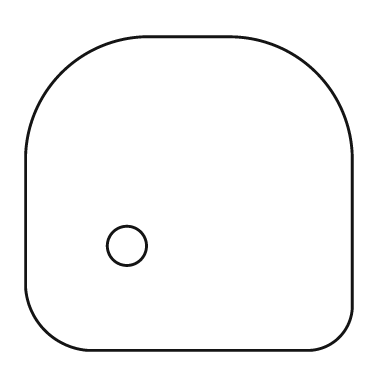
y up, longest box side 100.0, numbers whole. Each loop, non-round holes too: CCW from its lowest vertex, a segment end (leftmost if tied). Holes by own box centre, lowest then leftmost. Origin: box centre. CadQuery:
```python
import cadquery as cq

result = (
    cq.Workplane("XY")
    .moveTo(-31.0, -48.0)
    .lineTo(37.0, -48.0)
    .threePointArc((46.0, -44.0), (50.0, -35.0))
    .lineTo(50.0, 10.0)
    .threePointArc((39.0, 37.0), (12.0, 48.0))
    .lineTo(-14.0, 48.0)
    .threePointArc((-39.0, 37.0), (-50.0, 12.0))
    .lineTo(-50.0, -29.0)
    .threePointArc((-44.0, -42.0), (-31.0, -48.0))
    .close()
    .moveTo(-19.0, -16.0)
    .circle(6.0)
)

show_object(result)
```